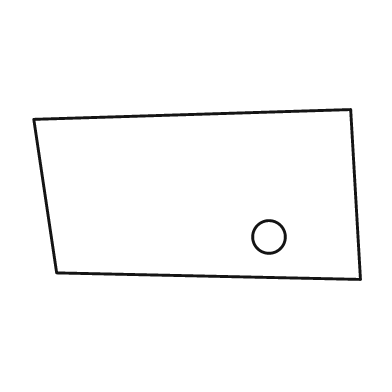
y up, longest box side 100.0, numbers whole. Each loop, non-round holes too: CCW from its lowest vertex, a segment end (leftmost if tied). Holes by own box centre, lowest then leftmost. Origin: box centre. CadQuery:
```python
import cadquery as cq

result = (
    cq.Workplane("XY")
    .moveTo(50.0, -26.0)
    .lineTo(47.0, 26.0)
    .lineTo(-50.0, 23.0)
    .lineTo(-43.0, -24.0)
    .close()
    .moveTo(22.0, -13.0)
    .circle(5.0)
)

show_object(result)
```